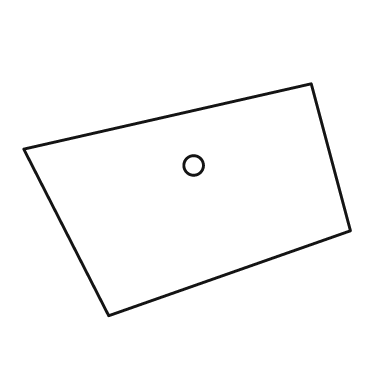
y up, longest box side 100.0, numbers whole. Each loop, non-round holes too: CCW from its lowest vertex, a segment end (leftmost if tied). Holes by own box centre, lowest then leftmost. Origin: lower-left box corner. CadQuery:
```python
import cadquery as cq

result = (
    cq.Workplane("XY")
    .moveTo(26.0, 0.0)
    .lineTo(100.0, 26.0)
    .lineTo(88.0, 71.0)
    .lineTo(0.0, 51.0)
    .close()
    .moveTo(52.0, 46.0)
    .circle(3.0)
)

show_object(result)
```